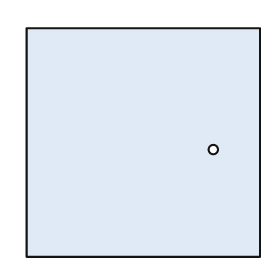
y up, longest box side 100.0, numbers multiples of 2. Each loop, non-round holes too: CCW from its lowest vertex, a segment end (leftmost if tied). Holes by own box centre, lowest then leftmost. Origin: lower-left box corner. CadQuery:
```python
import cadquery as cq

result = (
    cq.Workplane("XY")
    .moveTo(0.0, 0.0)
    .lineTo(100.0, 0.0)
    .lineTo(100.0, 98.0)
    .lineTo(0.0, 98.0)
    .close()
    .moveTo(80.0, 46.0)
    .circle(2.0)
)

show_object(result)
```